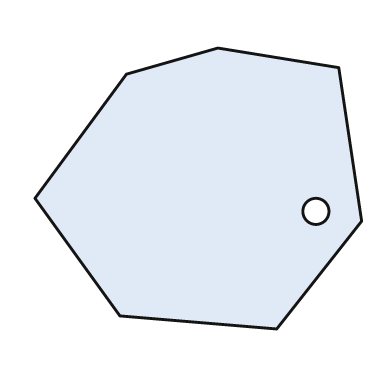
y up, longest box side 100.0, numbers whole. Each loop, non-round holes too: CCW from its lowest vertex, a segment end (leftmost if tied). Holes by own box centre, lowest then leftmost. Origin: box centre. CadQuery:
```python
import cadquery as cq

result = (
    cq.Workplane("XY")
    .moveTo(24.0, -43.0)
    .lineTo(50.0, -10.0)
    .lineTo(43.0, 37.0)
    .lineTo(6.0, 43.0)
    .lineTo(-22.0, 35.0)
    .lineTo(-50.0, -3.0)
    .lineTo(-24.0, -39.0)
    .close()
    .moveTo(36.0, -7.0)
    .circle(4.0)
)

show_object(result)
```